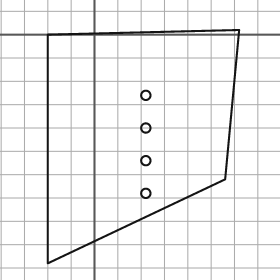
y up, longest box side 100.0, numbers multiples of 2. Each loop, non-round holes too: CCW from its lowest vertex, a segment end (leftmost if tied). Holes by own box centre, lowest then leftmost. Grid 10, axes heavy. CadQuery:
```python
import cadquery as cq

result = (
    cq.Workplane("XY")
    .moveTo(-20.0, -98.0)
    .lineTo(56.0, -62.0)
    .lineTo(62.0, 2.0)
    .lineTo(-20.0, 0.0)
    .close()
    .moveTo(22.0, -68.0)
    .circle(2.0)
    .moveTo(22.0, -54.0)
    .circle(2.0)
    .moveTo(22.0, -40.0)
    .circle(2.0)
    .moveTo(22.0, -26.0)
    .circle(2.0)
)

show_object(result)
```